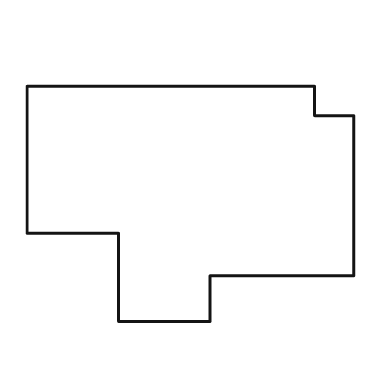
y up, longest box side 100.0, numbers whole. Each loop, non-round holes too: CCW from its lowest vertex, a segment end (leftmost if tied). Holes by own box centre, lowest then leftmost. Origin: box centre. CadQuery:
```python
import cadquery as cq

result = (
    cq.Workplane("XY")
    .moveTo(-22.0, -36.0)
    .lineTo(6.0, -36.0)
    .lineTo(6.0, -22.0)
    .lineTo(50.0, -22.0)
    .lineTo(50.0, 27.0)
    .lineTo(38.0, 27.0)
    .lineTo(38.0, 36.0)
    .lineTo(-50.0, 36.0)
    .lineTo(-50.0, -9.0)
    .lineTo(-22.0, -9.0)
    .close()
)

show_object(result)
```